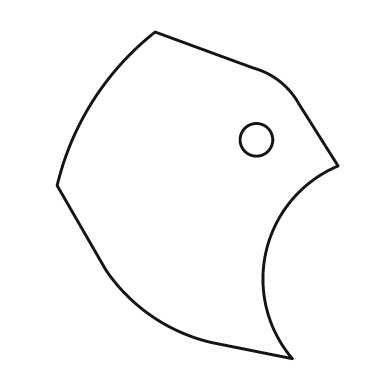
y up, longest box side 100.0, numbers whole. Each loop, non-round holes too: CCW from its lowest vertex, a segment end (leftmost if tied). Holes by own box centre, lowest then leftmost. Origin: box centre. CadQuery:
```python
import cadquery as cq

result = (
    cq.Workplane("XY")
    .moveTo(29.0, -50.0)
    .threePointArc((21.0, -17.0), (43.0, 9.0))
    .lineTo(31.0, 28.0)
    .threePointArc((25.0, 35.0), (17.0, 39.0))
    .lineTo(-13.0, 50.0)
    .threePointArc((-32.0, 29.0), (-43.0, 3.0))
    .lineTo(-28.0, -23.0)
    .threePointArc((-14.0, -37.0), (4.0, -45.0))
    .close()
    .moveTo(18.0, 17.0)
    .circle(5.0)
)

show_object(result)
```